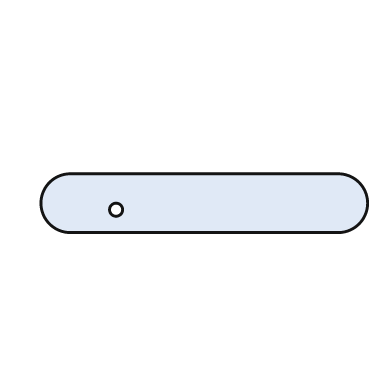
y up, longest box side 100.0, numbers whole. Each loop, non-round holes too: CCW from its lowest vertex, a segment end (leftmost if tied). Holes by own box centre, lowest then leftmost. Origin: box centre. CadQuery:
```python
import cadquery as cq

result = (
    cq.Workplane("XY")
    .moveTo(-41.0, -9.0)
    .lineTo(41.0, -9.0)
    .threePointArc((50.0, 0.0), (41.0, 9.0))
    .lineTo(-41.0, 9.0)
    .threePointArc((-50.0, 0.0), (-41.0, -9.0))
    .close()
    .moveTo(-27.0, -2.0)
    .circle(2.0)
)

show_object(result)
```